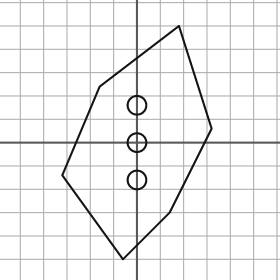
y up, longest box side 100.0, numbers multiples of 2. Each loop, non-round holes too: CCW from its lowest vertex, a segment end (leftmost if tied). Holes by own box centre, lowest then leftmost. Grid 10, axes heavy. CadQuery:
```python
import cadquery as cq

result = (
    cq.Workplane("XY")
    .moveTo(-6.0, -50.0)
    .lineTo(14.0, -30.0)
    .lineTo(32.0, 6.0)
    .lineTo(18.0, 50.0)
    .lineTo(-16.0, 24.0)
    .lineTo(-32.0, -14.0)
    .close()
    .moveTo(0.0, -16.0)
    .circle(4.0)
    .moveTo(0.0, 0.0)
    .circle(4.0)
    .moveTo(0.0, 16.0)
    .circle(4.0)
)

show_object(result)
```